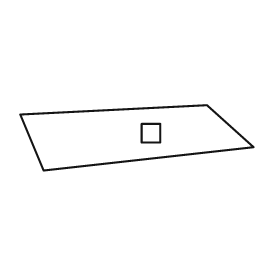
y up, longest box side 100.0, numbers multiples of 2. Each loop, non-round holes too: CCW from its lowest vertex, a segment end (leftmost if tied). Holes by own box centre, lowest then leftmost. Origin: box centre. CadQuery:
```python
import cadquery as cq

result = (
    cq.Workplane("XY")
    .moveTo(-40.0, -14.0)
    .lineTo(50.0, -4.0)
    .lineTo(30.0, 14.0)
    .lineTo(-50.0, 10.0)
    .close()
    .moveTo(2.0, -2.0)
    .lineTo(10.0, -2.0)
    .lineTo(10.0, 6.0)
    .lineTo(2.0, 6.0)
    .close()
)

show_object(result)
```